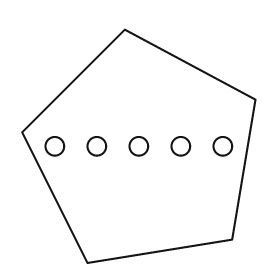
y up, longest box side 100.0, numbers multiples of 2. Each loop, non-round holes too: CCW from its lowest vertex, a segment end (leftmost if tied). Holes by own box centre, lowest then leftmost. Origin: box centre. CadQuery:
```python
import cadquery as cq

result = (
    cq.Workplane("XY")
    .moveTo(-22.0, -50.0)
    .lineTo(40.0, -40.0)
    .lineTo(50.0, 20.0)
    .lineTo(-6.0, 50.0)
    .lineTo(-50.0, 6.0)
    .close()
    .moveTo(-36.0, 0.0)
    .circle(4.0)
    .moveTo(-18.0, 0.0)
    .circle(4.0)
    .moveTo(0.0, 0.0)
    .circle(4.0)
    .moveTo(18.0, 0.0)
    .circle(4.0)
    .moveTo(36.0, 0.0)
    .circle(4.0)
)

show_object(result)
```